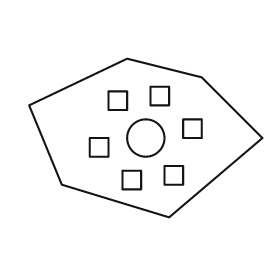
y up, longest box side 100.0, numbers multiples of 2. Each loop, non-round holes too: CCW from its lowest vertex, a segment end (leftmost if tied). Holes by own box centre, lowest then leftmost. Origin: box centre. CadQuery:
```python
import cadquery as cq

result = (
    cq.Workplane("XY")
    .moveTo(10.0, -34.0)
    .lineTo(50.0, 0.0)
    .lineTo(24.0, 26.0)
    .lineTo(-8.0, 34.0)
    .lineTo(-50.0, 14.0)
    .lineTo(-36.0, -20.0)
    .close()
    .moveTo(-10.0, -22.0)
    .lineTo(-2.0, -22.0)
    .lineTo(-2.0, -14.0)
    .lineTo(-10.0, -14.0)
    .close()
    .moveTo(8.0, -20.0)
    .lineTo(16.0, -20.0)
    .lineTo(16.0, -12.0)
    .lineTo(8.0, -12.0)
    .close()
    .moveTo(-24.0, -8.0)
    .lineTo(-16.0, -8.0)
    .lineTo(-16.0, 0.0)
    .lineTo(-24.0, 0.0)
    .close()
    .moveTo(0.0, 0.0)
    .circle(8.0)
    .moveTo(16.0, 0.0)
    .lineTo(24.0, 0.0)
    .lineTo(24.0, 8.0)
    .lineTo(16.0, 8.0)
    .close()
    .moveTo(-16.0, 12.0)
    .lineTo(-8.0, 12.0)
    .lineTo(-8.0, 20.0)
    .lineTo(-16.0, 20.0)
    .close()
    .moveTo(2.0, 14.0)
    .lineTo(10.0, 14.0)
    .lineTo(10.0, 22.0)
    .lineTo(2.0, 22.0)
    .close()
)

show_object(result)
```